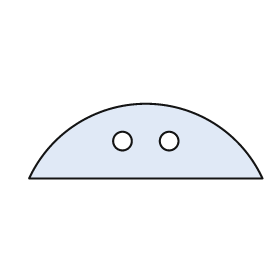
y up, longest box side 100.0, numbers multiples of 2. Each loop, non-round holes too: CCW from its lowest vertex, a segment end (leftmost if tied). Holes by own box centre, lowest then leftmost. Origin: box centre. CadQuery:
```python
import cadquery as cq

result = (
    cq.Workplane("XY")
    .moveTo(-50.0, -16.0)
    .lineTo(50.0, -16.0)
    .threePointArc((0.0, 16.0), (-50.0, -16.0))
    .close()
    .moveTo(-10.0, 0.0)
    .circle(4.0)
    .moveTo(10.0, 0.0)
    .circle(4.0)
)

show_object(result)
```